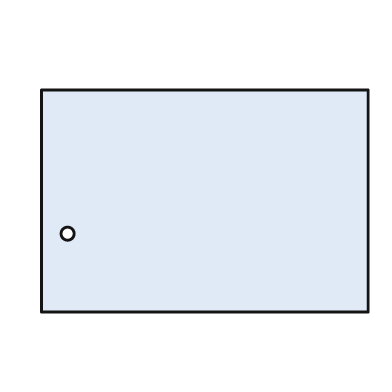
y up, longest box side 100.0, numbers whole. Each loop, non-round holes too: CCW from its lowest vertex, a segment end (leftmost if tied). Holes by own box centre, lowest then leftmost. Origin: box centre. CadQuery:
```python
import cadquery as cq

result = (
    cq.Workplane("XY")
    .moveTo(-50.0, -34.0)
    .lineTo(50.0, -34.0)
    .lineTo(50.0, 34.0)
    .lineTo(-50.0, 34.0)
    .close()
    .moveTo(-42.0, -10.0)
    .circle(2.0)
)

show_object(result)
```